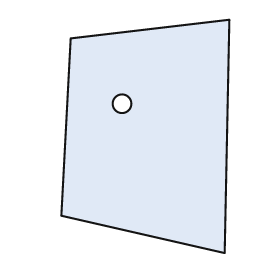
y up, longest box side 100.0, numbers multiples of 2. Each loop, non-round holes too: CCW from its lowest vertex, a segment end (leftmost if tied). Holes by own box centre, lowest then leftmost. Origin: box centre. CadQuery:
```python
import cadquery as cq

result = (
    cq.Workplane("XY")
    .moveTo(34.0, -50.0)
    .lineTo(36.0, 50.0)
    .lineTo(-32.0, 42.0)
    .lineTo(-36.0, -34.0)
    .close()
    .moveTo(-10.0, 14.0)
    .circle(4.0)
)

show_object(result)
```